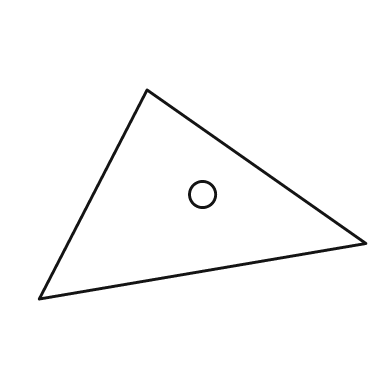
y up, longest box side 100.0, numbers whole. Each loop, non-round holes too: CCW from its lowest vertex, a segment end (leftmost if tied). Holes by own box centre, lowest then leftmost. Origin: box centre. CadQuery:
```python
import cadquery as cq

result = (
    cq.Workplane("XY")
    .moveTo(-50.0, -32.0)
    .lineTo(50.0, -15.0)
    .lineTo(-17.0, 32.0)
    .close()
    .moveTo(0.0, 0.0)
    .circle(4.0)
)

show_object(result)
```